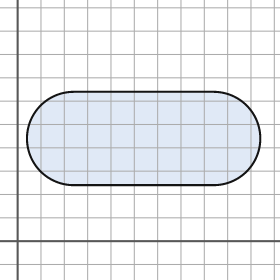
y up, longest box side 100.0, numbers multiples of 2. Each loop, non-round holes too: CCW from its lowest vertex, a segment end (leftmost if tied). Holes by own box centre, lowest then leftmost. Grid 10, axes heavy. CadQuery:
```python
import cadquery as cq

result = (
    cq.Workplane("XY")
    .moveTo(24.0, 24.0)
    .lineTo(84.0, 24.0)
    .threePointArc((104.0, 44.0), (84.0, 64.0))
    .lineTo(24.0, 64.0)
    .threePointArc((4.0, 44.0), (24.0, 24.0))
    .close()
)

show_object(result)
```